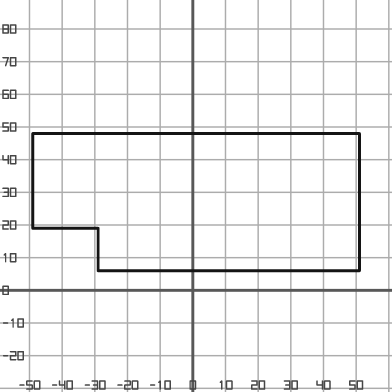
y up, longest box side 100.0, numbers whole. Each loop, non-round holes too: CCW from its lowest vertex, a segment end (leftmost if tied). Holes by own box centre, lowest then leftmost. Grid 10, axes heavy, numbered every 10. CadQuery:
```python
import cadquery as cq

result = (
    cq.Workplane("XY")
    .moveTo(-29.0, 6.0)
    .lineTo(51.0, 6.0)
    .lineTo(51.0, 48.0)
    .lineTo(-49.0, 48.0)
    .lineTo(-49.0, 19.0)
    .lineTo(-29.0, 19.0)
    .close()
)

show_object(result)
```